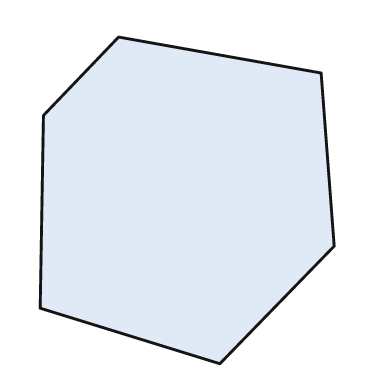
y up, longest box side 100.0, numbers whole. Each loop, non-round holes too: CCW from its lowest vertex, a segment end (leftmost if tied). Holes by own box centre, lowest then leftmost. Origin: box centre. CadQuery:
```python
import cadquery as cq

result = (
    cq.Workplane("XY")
    .moveTo(10.0, -50.0)
    .lineTo(45.0, -14.0)
    .lineTo(41.0, 39.0)
    .lineTo(-21.0, 50.0)
    .lineTo(-44.0, 26.0)
    .lineTo(-45.0, -33.0)
    .close()
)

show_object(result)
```